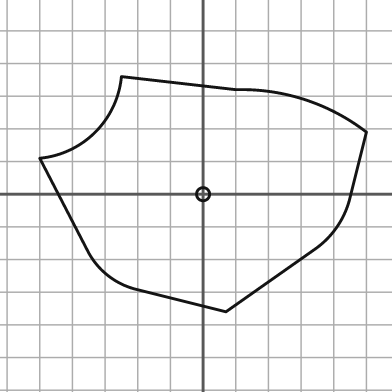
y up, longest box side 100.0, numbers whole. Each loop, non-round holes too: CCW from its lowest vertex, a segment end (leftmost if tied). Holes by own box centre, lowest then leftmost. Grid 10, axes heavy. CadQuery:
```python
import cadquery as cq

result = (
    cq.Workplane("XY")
    .moveTo(7.0, -36.0)
    .lineTo(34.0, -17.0)
    .threePointArc((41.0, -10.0), (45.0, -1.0))
    .lineTo(50.0, 19.0)
    .threePointArc((31.0, 29.0), (10.0, 32.0))
    .lineTo(-25.0, 36.0)
    .threePointArc((-33.0, 19.0), (-50.0, 11.0))
    .lineTo(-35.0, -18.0)
    .threePointArc((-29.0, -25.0), (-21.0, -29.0))
    .close()
    .moveTo(0.0, 0.0)
    .circle(2.0)
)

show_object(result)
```